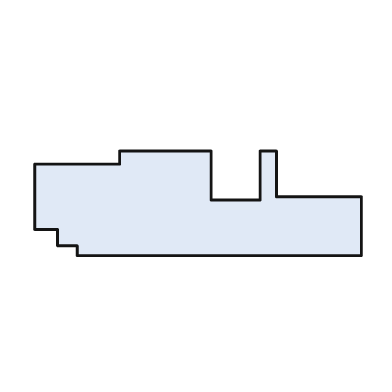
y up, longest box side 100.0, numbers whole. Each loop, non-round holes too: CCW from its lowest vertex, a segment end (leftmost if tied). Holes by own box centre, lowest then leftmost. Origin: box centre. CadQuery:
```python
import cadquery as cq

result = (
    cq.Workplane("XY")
    .moveTo(-37.0, -16.0)
    .lineTo(50.0, -16.0)
    .lineTo(50.0, 2.0)
    .lineTo(24.0, 2.0)
    .lineTo(24.0, 16.0)
    .lineTo(19.0, 16.0)
    .lineTo(19.0, 1.0)
    .lineTo(4.0, 1.0)
    .lineTo(4.0, 16.0)
    .lineTo(-24.0, 16.0)
    .lineTo(-24.0, 12.0)
    .lineTo(-50.0, 12.0)
    .lineTo(-50.0, -8.0)
    .lineTo(-43.0, -8.0)
    .lineTo(-43.0, -13.0)
    .lineTo(-37.0, -13.0)
    .close()
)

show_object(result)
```